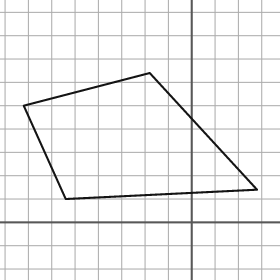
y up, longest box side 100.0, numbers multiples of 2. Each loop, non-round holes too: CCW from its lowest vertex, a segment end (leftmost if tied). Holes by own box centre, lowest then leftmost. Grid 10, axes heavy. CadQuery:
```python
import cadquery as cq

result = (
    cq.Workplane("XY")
    .moveTo(-54.0, 10.0)
    .lineTo(28.0, 14.0)
    .lineTo(-18.0, 64.0)
    .lineTo(-72.0, 50.0)
    .close()
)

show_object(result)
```